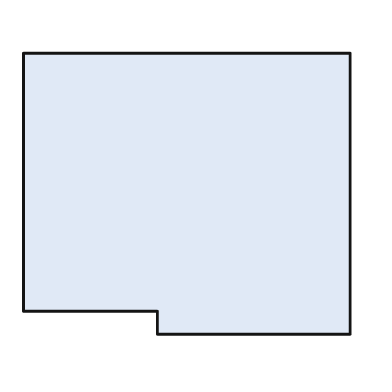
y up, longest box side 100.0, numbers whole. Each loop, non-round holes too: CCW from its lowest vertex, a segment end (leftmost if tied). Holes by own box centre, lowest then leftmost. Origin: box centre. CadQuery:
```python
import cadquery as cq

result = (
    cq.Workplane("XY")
    .moveTo(-9.0, -43.0)
    .lineTo(50.0, -43.0)
    .lineTo(50.0, 43.0)
    .lineTo(-50.0, 43.0)
    .lineTo(-50.0, -36.0)
    .lineTo(-9.0, -36.0)
    .close()
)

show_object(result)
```